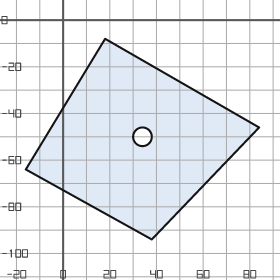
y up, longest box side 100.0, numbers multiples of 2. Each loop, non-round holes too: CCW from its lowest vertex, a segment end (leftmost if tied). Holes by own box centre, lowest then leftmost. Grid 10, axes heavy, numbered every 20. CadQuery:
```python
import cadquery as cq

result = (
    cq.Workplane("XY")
    .moveTo(38.0, -94.0)
    .lineTo(84.0, -46.0)
    .lineTo(18.0, -8.0)
    .lineTo(-16.0, -64.0)
    .close()
    .moveTo(34.0, -50.0)
    .circle(4.0)
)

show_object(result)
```